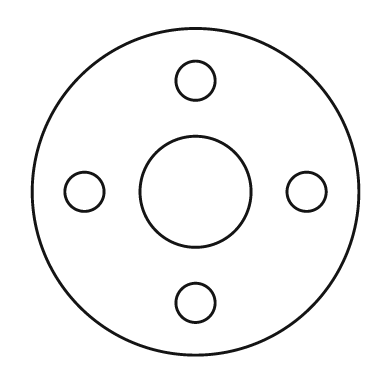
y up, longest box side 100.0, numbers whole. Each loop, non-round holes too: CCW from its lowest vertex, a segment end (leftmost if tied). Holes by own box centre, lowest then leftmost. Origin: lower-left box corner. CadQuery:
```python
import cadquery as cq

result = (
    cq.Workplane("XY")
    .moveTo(50.0, 50.0)
    .circle(50.0)
    .moveTo(50.0, 16.0)
    .circle(6.0)
    .moveTo(16.0, 50.0)
    .circle(6.0)
    .moveTo(50.0, 50.0)
    .circle(17.0)
    .moveTo(84.0, 50.0)
    .circle(6.0)
    .moveTo(50.0, 84.0)
    .circle(6.0)
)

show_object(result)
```